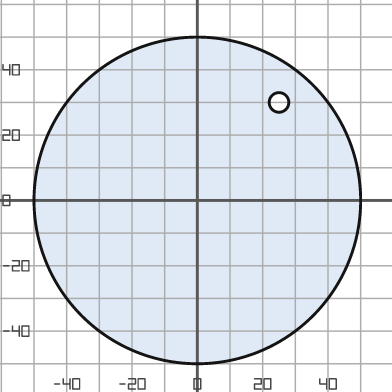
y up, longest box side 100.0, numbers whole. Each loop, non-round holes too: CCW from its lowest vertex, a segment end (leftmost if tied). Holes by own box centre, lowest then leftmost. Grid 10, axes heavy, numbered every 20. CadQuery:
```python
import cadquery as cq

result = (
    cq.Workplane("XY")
    .moveTo(0.0, 0.0)
    .circle(50.0)
    .moveTo(25.0, 30.0)
    .circle(3.0)
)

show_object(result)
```